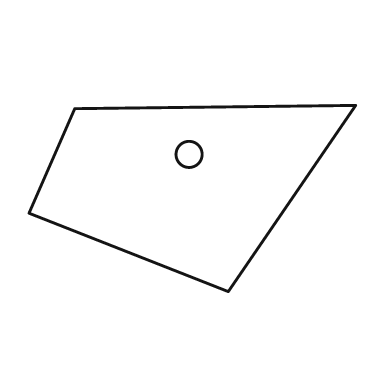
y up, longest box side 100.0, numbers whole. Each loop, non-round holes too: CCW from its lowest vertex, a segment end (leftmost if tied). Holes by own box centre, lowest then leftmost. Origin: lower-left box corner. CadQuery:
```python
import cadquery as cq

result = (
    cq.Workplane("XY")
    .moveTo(61.0, 0.0)
    .lineTo(100.0, 57.0)
    .lineTo(14.0, 56.0)
    .lineTo(0.0, 24.0)
    .close()
    .moveTo(49.0, 42.0)
    .circle(4.0)
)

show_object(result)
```